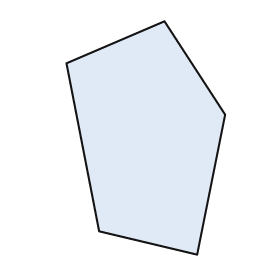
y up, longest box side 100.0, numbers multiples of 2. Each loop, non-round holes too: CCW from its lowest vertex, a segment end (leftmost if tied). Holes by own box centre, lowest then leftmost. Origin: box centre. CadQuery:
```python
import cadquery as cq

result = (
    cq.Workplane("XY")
    .moveTo(22.0, -50.0)
    .lineTo(34.0, 10.0)
    .lineTo(8.0, 50.0)
    .lineTo(-34.0, 32.0)
    .lineTo(-20.0, -40.0)
    .close()
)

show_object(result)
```